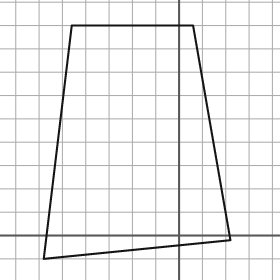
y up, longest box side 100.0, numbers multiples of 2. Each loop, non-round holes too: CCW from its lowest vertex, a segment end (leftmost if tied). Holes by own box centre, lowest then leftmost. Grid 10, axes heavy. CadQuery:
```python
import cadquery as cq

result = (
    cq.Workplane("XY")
    .moveTo(-58.0, -10.0)
    .lineTo(22.0, -2.0)
    .lineTo(6.0, 90.0)
    .lineTo(-46.0, 90.0)
    .close()
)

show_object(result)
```